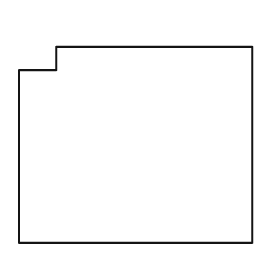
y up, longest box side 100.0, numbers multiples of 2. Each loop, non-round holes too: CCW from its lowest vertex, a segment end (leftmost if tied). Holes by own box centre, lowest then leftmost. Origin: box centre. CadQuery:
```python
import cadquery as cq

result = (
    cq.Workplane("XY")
    .moveTo(-50.0, -42.0)
    .lineTo(50.0, -42.0)
    .lineTo(50.0, 42.0)
    .lineTo(-34.0, 42.0)
    .lineTo(-34.0, 32.0)
    .lineTo(-50.0, 32.0)
    .close()
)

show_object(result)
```